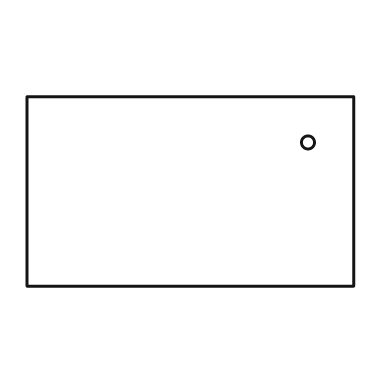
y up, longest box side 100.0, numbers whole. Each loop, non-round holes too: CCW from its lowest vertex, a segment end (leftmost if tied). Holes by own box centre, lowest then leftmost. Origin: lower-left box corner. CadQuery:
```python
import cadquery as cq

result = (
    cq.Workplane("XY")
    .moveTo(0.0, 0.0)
    .lineTo(100.0, 0.0)
    .lineTo(100.0, 58.0)
    .lineTo(0.0, 58.0)
    .close()
    .moveTo(86.0, 44.0)
    .circle(2.0)
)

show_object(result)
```